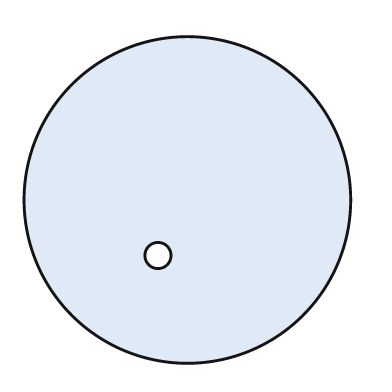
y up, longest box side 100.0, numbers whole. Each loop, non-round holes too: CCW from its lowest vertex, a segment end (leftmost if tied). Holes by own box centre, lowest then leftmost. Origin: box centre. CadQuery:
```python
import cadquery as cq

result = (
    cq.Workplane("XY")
    .moveTo(0.0, 0.0)
    .circle(50.0)
    .moveTo(-9.0, -17.0)
    .circle(4.0)
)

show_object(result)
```